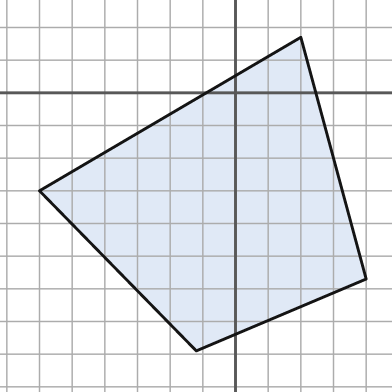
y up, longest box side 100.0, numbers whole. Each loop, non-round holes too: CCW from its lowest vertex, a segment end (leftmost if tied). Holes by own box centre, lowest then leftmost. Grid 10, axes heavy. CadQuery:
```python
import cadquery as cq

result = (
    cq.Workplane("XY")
    .moveTo(-12.0, -79.0)
    .lineTo(40.0, -57.0)
    .lineTo(20.0, 17.0)
    .lineTo(-60.0, -30.0)
    .close()
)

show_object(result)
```